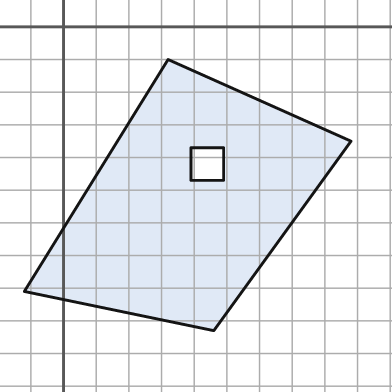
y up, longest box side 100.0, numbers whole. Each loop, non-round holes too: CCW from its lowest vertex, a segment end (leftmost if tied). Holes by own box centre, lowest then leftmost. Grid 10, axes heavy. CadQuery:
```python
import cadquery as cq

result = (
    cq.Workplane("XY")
    .moveTo(46.0, -93.0)
    .lineTo(88.0, -35.0)
    .lineTo(32.0, -10.0)
    .lineTo(-12.0, -81.0)
    .close()
    .moveTo(39.0, -47.0)
    .lineTo(49.0, -47.0)
    .lineTo(49.0, -37.0)
    .lineTo(39.0, -37.0)
    .close()
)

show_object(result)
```